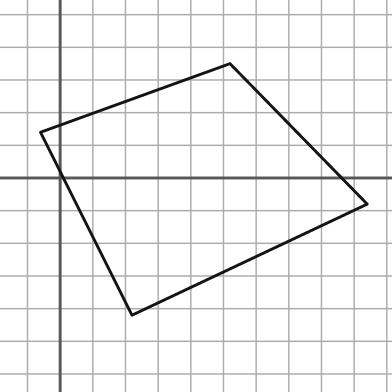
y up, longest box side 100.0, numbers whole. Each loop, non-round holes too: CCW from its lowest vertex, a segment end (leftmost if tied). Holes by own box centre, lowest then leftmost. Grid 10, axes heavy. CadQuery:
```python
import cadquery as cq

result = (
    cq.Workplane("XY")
    .moveTo(22.0, -42.0)
    .lineTo(94.0, -8.0)
    .lineTo(52.0, 35.0)
    .lineTo(-6.0, 14.0)
    .close()
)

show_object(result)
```